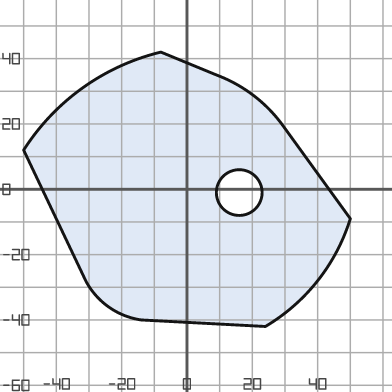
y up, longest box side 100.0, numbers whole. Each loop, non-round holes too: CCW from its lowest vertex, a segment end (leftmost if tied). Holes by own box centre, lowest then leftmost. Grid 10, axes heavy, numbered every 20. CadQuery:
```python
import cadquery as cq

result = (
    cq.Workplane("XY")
    .moveTo(24.0, -42.0)
    .threePointArc((40.0, -28.0), (50.0, -9.0))
    .lineTo(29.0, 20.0)
    .threePointArc((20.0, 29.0), (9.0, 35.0))
    .lineTo(-8.0, 42.0)
    .threePointArc((-32.0, 31.0), (-50.0, 12.0))
    .lineTo(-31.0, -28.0)
    .threePointArc((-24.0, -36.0), (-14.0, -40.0))
    .close()
    .moveTo(16.0, -1.0)
    .circle(7.0)
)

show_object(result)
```